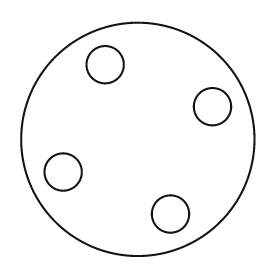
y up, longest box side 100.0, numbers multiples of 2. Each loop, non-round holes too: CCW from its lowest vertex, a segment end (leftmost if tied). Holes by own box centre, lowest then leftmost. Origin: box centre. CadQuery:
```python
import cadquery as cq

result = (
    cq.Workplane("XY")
    .moveTo(0.0, 0.0)
    .circle(50.0)
    .moveTo(14.0, -32.0)
    .circle(8.0)
    .moveTo(-32.0, -14.0)
    .circle(8.0)
    .moveTo(32.0, 14.0)
    .circle(8.0)
    .moveTo(-14.0, 32.0)
    .circle(8.0)
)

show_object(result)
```